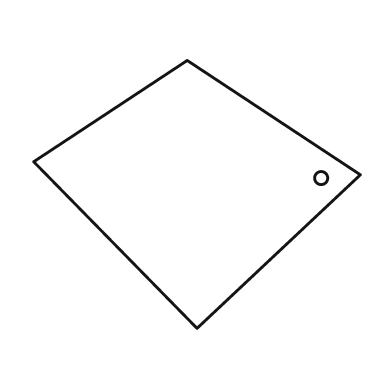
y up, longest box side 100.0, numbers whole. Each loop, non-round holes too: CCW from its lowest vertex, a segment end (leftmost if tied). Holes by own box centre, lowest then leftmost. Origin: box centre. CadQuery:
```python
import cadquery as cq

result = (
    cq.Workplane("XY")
    .moveTo(0.0, -41.0)
    .lineTo(50.0, 6.0)
    .lineTo(-3.0, 41.0)
    .lineTo(-50.0, 10.0)
    .close()
    .moveTo(38.0, 5.0)
    .circle(2.0)
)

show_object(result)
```